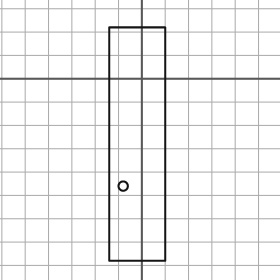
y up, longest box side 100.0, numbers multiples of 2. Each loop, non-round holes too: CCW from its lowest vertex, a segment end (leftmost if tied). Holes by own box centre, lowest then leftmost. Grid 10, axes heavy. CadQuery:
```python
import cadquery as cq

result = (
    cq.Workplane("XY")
    .moveTo(-14.0, -78.0)
    .lineTo(10.0, -78.0)
    .lineTo(10.0, 22.0)
    .lineTo(-14.0, 22.0)
    .close()
    .moveTo(-8.0, -46.0)
    .circle(2.0)
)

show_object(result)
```